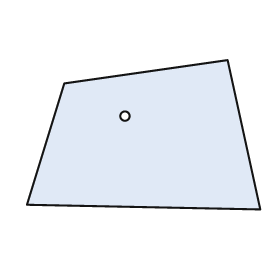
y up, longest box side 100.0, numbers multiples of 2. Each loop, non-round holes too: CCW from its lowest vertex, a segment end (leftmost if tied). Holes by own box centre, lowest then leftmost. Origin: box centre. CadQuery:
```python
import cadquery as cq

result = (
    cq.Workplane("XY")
    .moveTo(50.0, -32.0)
    .lineTo(36.0, 32.0)
    .lineTo(-34.0, 22.0)
    .lineTo(-50.0, -30.0)
    .close()
    .moveTo(-8.0, 8.0)
    .circle(2.0)
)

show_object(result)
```